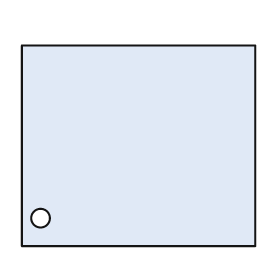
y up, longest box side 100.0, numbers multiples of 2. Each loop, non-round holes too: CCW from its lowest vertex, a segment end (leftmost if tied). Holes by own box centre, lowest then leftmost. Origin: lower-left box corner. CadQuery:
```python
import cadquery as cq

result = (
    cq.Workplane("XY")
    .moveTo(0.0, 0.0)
    .lineTo(100.0, 0.0)
    .lineTo(100.0, 86.0)
    .lineTo(0.0, 86.0)
    .close()
    .moveTo(8.0, 12.0)
    .circle(4.0)
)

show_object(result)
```